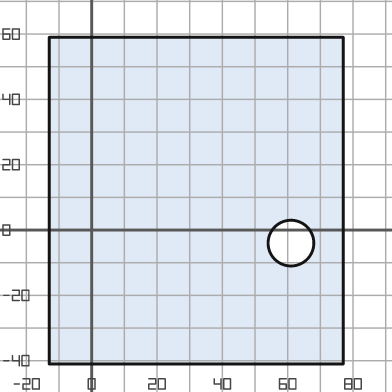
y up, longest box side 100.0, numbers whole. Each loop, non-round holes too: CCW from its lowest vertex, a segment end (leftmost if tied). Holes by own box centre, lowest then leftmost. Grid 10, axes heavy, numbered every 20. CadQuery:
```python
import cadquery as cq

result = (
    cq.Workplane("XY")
    .moveTo(-13.0, -41.0)
    .lineTo(77.0, -41.0)
    .lineTo(77.0, 59.0)
    .lineTo(-13.0, 59.0)
    .close()
    .moveTo(61.0, -4.0)
    .circle(7.0)
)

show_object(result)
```